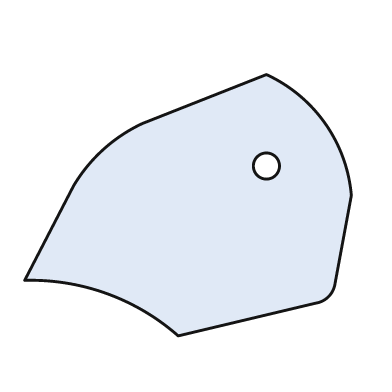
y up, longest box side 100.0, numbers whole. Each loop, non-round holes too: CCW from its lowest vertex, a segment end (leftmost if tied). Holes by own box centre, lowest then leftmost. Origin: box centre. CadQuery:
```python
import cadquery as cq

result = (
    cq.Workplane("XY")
    .moveTo(-3.0, -40.0)
    .lineTo(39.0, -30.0)
    .threePointArc((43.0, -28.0), (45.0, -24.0))
    .lineTo(50.0, 3.0)
    .threePointArc((42.0, 25.0), (24.0, 40.0))
    .lineTo(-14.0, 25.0)
    .threePointArc((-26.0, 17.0), (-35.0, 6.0))
    .lineTo(-50.0, -23.0)
    .threePointArc((-25.0, -27.0), (-3.0, -40.0))
    .close()
    .moveTo(24.0, 12.0)
    .circle(4.0)
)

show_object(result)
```